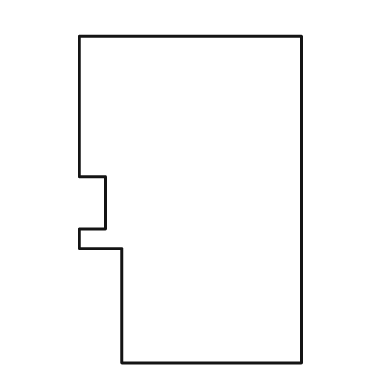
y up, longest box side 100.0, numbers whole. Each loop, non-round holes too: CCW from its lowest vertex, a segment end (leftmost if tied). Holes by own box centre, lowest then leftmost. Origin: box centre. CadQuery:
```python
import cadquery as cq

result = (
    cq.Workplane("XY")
    .moveTo(-21.0, -50.0)
    .lineTo(34.0, -50.0)
    .lineTo(34.0, 50.0)
    .lineTo(-34.0, 50.0)
    .lineTo(-34.0, 7.0)
    .lineTo(-26.0, 7.0)
    .lineTo(-26.0, -9.0)
    .lineTo(-34.0, -9.0)
    .lineTo(-34.0, -15.0)
    .lineTo(-21.0, -15.0)
    .close()
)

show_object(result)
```